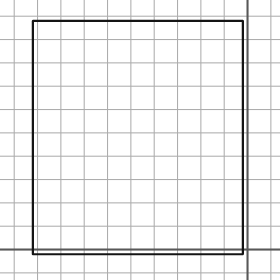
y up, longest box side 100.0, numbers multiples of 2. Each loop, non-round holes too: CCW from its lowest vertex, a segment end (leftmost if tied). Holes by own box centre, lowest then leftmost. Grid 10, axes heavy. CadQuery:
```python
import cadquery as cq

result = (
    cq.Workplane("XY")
    .moveTo(-92.0, -2.0)
    .lineTo(-2.0, -2.0)
    .lineTo(-2.0, 98.0)
    .lineTo(-92.0, 98.0)
    .close()
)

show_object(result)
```